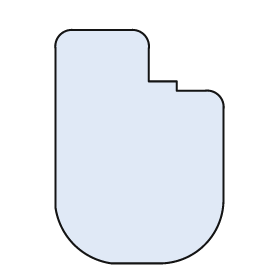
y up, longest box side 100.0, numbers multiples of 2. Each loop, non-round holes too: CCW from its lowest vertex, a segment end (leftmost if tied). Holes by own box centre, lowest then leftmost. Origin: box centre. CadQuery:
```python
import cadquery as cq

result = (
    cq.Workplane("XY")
    .moveTo(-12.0, -50.0)
    .lineTo(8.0, -50.0)
    .threePointArc((28.0, -42.0), (36.0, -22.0))
    .lineTo(36.0, 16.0)
    .threePointArc((34.0, 22.0), (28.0, 24.0))
    .lineTo(16.0, 24.0)
    .lineTo(16.0, 28.0)
    .lineTo(4.0, 28.0)
    .lineTo(4.0, 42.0)
    .threePointArc((2.0, 48.0), (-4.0, 50.0))
    .lineTo(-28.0, 50.0)
    .threePointArc((-34.0, 48.0), (-36.0, 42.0))
    .lineTo(-36.0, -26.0)
    .threePointArc((-28.0, -42.0), (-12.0, -50.0))
    .close()
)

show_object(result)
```